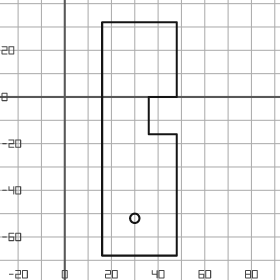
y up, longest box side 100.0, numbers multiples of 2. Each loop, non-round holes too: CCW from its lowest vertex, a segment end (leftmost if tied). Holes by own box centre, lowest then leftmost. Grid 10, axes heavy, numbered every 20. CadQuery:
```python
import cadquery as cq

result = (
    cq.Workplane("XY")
    .moveTo(16.0, -68.0)
    .lineTo(48.0, -68.0)
    .lineTo(48.0, -16.0)
    .lineTo(36.0, -16.0)
    .lineTo(36.0, 0.0)
    .lineTo(48.0, 0.0)
    .lineTo(48.0, 32.0)
    .lineTo(16.0, 32.0)
    .close()
    .moveTo(30.0, -52.0)
    .circle(2.0)
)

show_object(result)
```